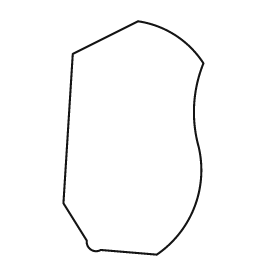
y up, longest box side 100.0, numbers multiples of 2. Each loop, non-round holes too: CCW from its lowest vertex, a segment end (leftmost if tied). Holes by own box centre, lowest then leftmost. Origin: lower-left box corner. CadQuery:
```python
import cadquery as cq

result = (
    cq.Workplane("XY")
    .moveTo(40.0, 0.0)
    .threePointArc((56.0, 20.0), (58.0, 46.0))
    .threePointArc((56.0, 64.0), (60.0, 82.0))
    .threePointArc((48.0, 94.0), (32.0, 100.0))
    .lineTo(4.0, 86.0)
    .lineTo(0.0, 22.0)
    .lineTo(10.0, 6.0)
    .threePointArc((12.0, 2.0), (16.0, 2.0))
    .close()
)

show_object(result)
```